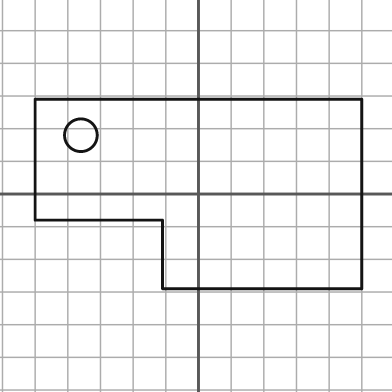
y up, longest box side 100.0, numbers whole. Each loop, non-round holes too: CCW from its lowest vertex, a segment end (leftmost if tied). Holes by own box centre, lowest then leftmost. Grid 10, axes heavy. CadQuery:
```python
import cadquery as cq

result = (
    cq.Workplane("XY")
    .moveTo(-11.0, -29.0)
    .lineTo(50.0, -29.0)
    .lineTo(50.0, 29.0)
    .lineTo(-50.0, 29.0)
    .lineTo(-50.0, -8.0)
    .lineTo(-11.0, -8.0)
    .close()
    .moveTo(-36.0, 18.0)
    .circle(5.0)
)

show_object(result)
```